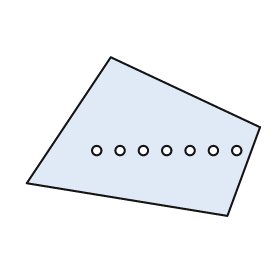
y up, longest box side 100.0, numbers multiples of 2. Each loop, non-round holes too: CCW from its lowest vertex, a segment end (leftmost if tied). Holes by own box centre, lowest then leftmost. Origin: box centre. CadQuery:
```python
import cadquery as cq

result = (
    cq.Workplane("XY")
    .moveTo(36.0, -34.0)
    .lineTo(50.0, 4.0)
    .lineTo(-14.0, 34.0)
    .lineTo(-50.0, -20.0)
    .close()
    .moveTo(-20.0, -6.0)
    .circle(2.0)
    .moveTo(-10.0, -6.0)
    .circle(2.0)
    .moveTo(0.0, -6.0)
    .circle(2.0)
    .moveTo(10.0, -6.0)
    .circle(2.0)
    .moveTo(20.0, -6.0)
    .circle(2.0)
    .moveTo(30.0, -6.0)
    .circle(2.0)
    .moveTo(40.0, -6.0)
    .circle(2.0)
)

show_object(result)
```